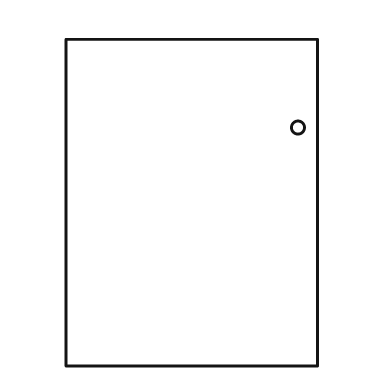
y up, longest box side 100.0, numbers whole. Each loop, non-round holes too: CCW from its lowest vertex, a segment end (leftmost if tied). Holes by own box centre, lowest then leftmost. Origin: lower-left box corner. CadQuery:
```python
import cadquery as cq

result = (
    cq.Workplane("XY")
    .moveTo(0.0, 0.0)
    .lineTo(77.0, 0.0)
    .lineTo(77.0, 100.0)
    .lineTo(0.0, 100.0)
    .close()
    .moveTo(71.0, 73.0)
    .circle(2.0)
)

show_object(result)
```